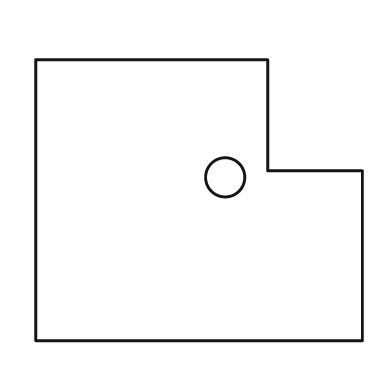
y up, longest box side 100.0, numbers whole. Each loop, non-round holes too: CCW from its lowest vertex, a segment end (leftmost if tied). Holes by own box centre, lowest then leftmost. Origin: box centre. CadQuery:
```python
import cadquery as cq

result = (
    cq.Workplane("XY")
    .moveTo(-50.0, -43.0)
    .lineTo(50.0, -43.0)
    .lineTo(50.0, 9.0)
    .lineTo(21.0, 9.0)
    .lineTo(21.0, 43.0)
    .lineTo(-50.0, 43.0)
    .close()
    .moveTo(8.0, 7.0)
    .circle(6.0)
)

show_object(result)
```